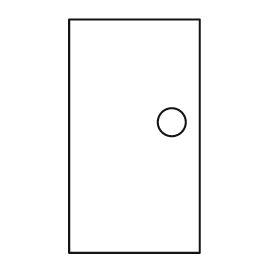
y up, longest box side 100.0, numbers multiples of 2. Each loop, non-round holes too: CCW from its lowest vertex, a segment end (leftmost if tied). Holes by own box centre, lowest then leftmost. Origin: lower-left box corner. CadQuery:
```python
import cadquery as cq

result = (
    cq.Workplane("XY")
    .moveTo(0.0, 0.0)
    .lineTo(56.0, 0.0)
    .lineTo(56.0, 100.0)
    .lineTo(0.0, 100.0)
    .close()
    .moveTo(44.0, 56.0)
    .circle(6.0)
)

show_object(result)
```